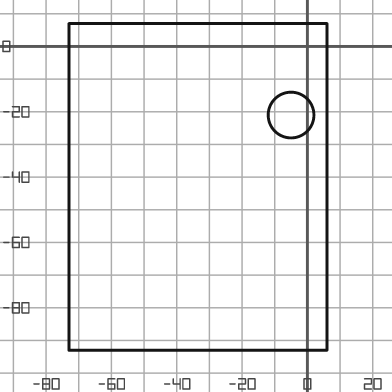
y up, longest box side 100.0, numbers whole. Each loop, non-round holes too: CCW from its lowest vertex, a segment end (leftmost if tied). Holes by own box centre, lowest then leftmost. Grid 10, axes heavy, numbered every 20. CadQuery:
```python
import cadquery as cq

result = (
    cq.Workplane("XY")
    .moveTo(-73.0, -93.0)
    .lineTo(6.0, -93.0)
    .lineTo(6.0, 7.0)
    .lineTo(-73.0, 7.0)
    .close()
    .moveTo(-5.0, -21.0)
    .circle(7.0)
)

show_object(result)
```